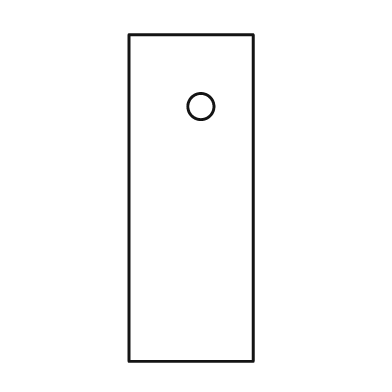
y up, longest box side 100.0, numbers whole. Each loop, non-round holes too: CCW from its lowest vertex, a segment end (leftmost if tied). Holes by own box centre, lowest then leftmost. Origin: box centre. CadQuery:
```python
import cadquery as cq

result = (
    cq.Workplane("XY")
    .moveTo(-19.0, -50.0)
    .lineTo(19.0, -50.0)
    .lineTo(19.0, 50.0)
    .lineTo(-19.0, 50.0)
    .close()
    .moveTo(3.0, 28.0)
    .circle(4.0)
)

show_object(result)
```